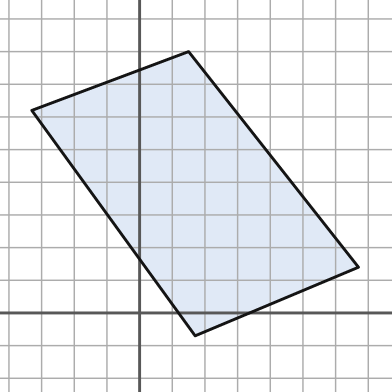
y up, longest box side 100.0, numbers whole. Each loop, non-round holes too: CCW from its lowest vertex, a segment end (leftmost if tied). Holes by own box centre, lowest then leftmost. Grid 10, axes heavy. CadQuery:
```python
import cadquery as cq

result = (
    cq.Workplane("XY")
    .moveTo(17.0, -7.0)
    .lineTo(67.0, 14.0)
    .lineTo(15.0, 80.0)
    .lineTo(-33.0, 62.0)
    .close()
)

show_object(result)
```